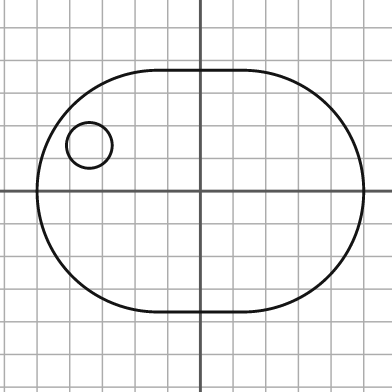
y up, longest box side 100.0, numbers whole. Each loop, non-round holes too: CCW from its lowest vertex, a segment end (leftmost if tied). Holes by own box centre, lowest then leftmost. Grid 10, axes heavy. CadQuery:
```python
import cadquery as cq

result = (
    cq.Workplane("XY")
    .moveTo(-13.0, -37.0)
    .lineTo(13.0, -37.0)
    .threePointArc((50.0, 0.0), (13.0, 37.0))
    .lineTo(-13.0, 37.0)
    .threePointArc((-50.0, 0.0), (-13.0, -37.0))
    .close()
    .moveTo(-34.0, 14.0)
    .circle(7.0)
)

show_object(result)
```